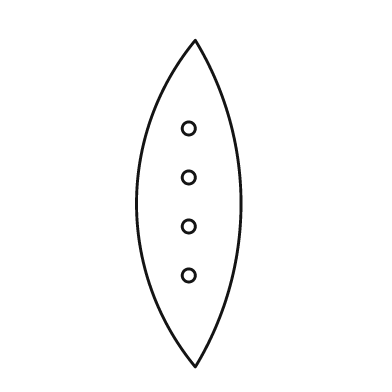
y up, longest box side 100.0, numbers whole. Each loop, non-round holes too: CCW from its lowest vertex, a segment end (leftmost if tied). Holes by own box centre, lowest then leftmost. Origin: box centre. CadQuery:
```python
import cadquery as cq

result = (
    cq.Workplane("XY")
    .moveTo(2.0, -50.0)
    .threePointArc((16.0, 0.0), (2.0, 50.0))
    .threePointArc((-16.0, 0.0), (2.0, -50.0))
    .close()
    .moveTo(0.0, -22.0)
    .circle(2.0)
    .moveTo(0.0, -7.0)
    .circle(2.0)
    .moveTo(0.0, 8.0)
    .circle(2.0)
    .moveTo(0.0, 23.0)
    .circle(2.0)
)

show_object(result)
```